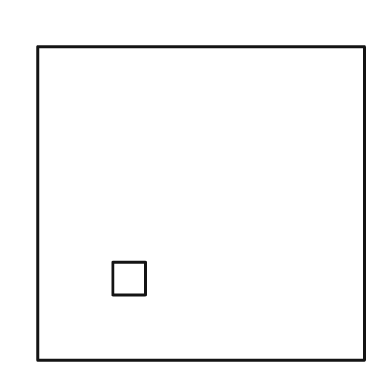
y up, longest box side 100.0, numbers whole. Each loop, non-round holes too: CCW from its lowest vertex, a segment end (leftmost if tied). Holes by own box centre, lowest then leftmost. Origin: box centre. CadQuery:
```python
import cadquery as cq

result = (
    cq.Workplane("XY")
    .moveTo(-50.0, -48.0)
    .lineTo(50.0, -48.0)
    .lineTo(50.0, 48.0)
    .lineTo(-50.0, 48.0)
    .close()
    .moveTo(-27.0, -28.0)
    .lineTo(-17.0, -28.0)
    .lineTo(-17.0, -18.0)
    .lineTo(-27.0, -18.0)
    .close()
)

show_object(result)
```